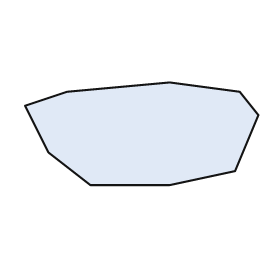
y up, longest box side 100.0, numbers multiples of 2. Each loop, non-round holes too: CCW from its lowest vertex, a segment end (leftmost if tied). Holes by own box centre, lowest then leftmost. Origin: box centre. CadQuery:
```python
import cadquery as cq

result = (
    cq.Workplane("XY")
    .moveTo(-22.0, -22.0)
    .lineTo(12.0, -22.0)
    .lineTo(40.0, -16.0)
    .lineTo(50.0, 8.0)
    .lineTo(42.0, 18.0)
    .lineTo(12.0, 22.0)
    .lineTo(-32.0, 18.0)
    .lineTo(-50.0, 12.0)
    .lineTo(-40.0, -8.0)
    .close()
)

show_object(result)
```